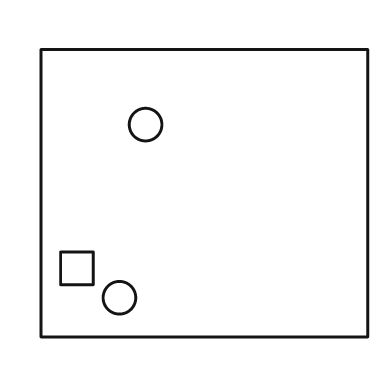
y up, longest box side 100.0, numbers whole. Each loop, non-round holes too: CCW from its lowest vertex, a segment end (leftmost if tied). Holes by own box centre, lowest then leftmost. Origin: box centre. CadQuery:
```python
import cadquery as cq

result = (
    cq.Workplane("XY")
    .moveTo(-50.0, -44.0)
    .lineTo(50.0, -44.0)
    .lineTo(50.0, 44.0)
    .lineTo(-50.0, 44.0)
    .close()
    .moveTo(-26.0, -32.0)
    .circle(5.0)
    .moveTo(-44.0, -28.0)
    .lineTo(-34.0, -28.0)
    .lineTo(-34.0, -18.0)
    .lineTo(-44.0, -18.0)
    .close()
    .moveTo(-18.0, 21.0)
    .circle(5.0)
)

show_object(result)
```